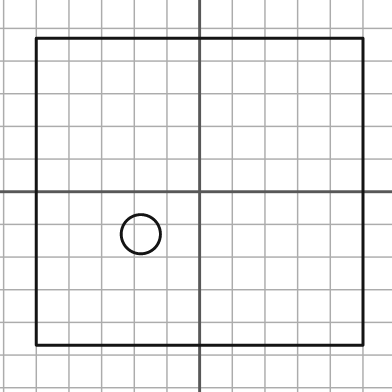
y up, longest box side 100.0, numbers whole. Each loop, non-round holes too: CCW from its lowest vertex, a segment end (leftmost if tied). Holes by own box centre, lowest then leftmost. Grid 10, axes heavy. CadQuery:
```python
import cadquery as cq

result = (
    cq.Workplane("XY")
    .moveTo(-50.0, -47.0)
    .lineTo(50.0, -47.0)
    .lineTo(50.0, 47.0)
    .lineTo(-50.0, 47.0)
    .close()
    .moveTo(-18.0, -13.0)
    .circle(6.0)
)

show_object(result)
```